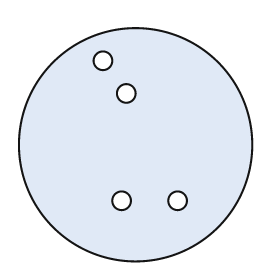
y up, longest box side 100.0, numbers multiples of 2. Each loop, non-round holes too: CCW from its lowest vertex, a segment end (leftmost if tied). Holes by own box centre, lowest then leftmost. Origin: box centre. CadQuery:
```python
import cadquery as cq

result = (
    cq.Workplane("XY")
    .moveTo(0.0, 0.0)
    .circle(50.0)
    .moveTo(-6.0, -24.0)
    .circle(4.0)
    .moveTo(18.0, -24.0)
    .circle(4.0)
    .moveTo(-4.0, 22.0)
    .circle(4.0)
    .moveTo(-14.0, 36.0)
    .circle(4.0)
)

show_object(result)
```